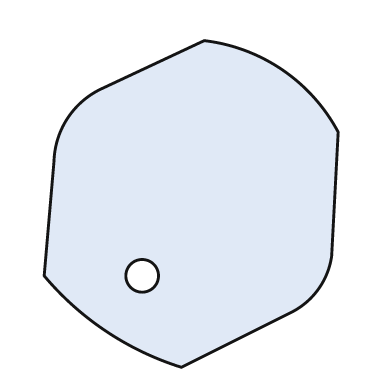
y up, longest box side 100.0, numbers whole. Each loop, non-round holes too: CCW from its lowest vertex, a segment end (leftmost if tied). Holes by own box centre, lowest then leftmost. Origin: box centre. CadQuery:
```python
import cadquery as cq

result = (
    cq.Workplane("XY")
    .moveTo(-3.0, -50.0)
    .lineTo(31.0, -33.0)
    .threePointArc((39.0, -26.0), (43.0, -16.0))
    .lineTo(45.0, 22.0)
    .threePointArc((28.0, 41.0), (4.0, 50.0))
    .lineTo(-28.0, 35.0)
    .threePointArc((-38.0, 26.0), (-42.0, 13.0))
    .lineTo(-45.0, -22.0)
    .threePointArc((-26.0, -39.0), (-3.0, -50.0))
    .close()
    .moveTo(-15.0, -22.0)
    .circle(5.0)
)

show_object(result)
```